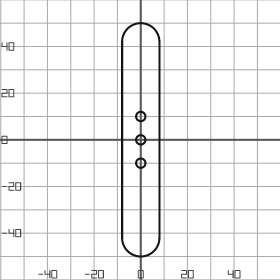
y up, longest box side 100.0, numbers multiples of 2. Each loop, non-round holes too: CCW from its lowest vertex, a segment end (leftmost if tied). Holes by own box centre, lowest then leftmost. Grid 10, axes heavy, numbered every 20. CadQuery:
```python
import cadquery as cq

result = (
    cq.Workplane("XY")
    .moveTo(-8.0, -42.0)
    .threePointArc((0.0, -50.0), (8.0, -42.0))
    .lineTo(8.0, 42.0)
    .threePointArc((0.0, 50.0), (-8.0, 42.0))
    .close()
    .moveTo(0.0, -10.0)
    .circle(2.0)
    .moveTo(0.0, 0.0)
    .circle(2.0)
    .moveTo(0.0, 10.0)
    .circle(2.0)
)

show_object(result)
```